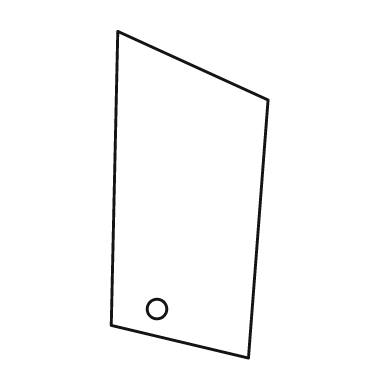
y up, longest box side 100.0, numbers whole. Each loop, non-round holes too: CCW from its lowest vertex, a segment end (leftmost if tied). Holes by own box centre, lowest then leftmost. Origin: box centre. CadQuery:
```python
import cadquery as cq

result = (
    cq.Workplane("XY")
    .moveTo(18.0, -50.0)
    .lineTo(24.0, 29.0)
    .lineTo(-22.0, 50.0)
    .lineTo(-24.0, -40.0)
    .close()
    .moveTo(-10.0, -35.0)
    .circle(3.0)
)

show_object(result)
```